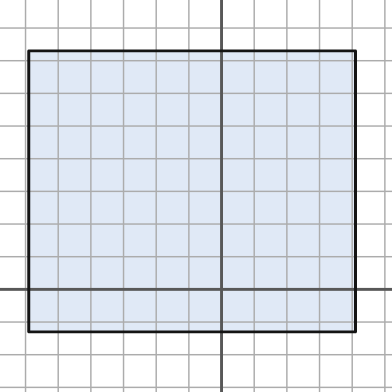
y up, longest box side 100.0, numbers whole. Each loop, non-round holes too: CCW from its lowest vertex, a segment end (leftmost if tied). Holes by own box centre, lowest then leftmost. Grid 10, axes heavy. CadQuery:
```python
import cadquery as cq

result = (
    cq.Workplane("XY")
    .moveTo(-59.0, -13.0)
    .lineTo(41.0, -13.0)
    .lineTo(41.0, 73.0)
    .lineTo(-59.0, 73.0)
    .close()
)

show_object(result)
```